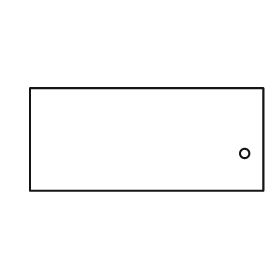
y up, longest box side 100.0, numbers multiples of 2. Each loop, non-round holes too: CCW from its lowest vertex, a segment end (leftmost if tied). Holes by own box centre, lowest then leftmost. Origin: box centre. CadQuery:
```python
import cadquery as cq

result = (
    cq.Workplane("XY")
    .moveTo(-50.0, -22.0)
    .lineTo(50.0, -22.0)
    .lineTo(50.0, 22.0)
    .lineTo(-50.0, 22.0)
    .close()
    .moveTo(42.0, -6.0)
    .circle(2.0)
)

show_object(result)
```